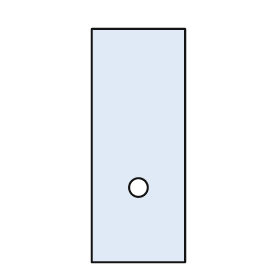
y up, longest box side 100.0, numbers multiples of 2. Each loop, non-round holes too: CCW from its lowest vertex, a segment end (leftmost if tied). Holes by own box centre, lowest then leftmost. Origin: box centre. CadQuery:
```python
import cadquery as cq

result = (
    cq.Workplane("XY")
    .moveTo(-20.0, -50.0)
    .lineTo(20.0, -50.0)
    .lineTo(20.0, 50.0)
    .lineTo(-20.0, 50.0)
    .close()
    .moveTo(0.0, -18.0)
    .circle(4.0)
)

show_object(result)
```